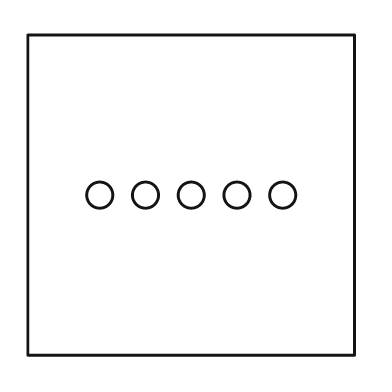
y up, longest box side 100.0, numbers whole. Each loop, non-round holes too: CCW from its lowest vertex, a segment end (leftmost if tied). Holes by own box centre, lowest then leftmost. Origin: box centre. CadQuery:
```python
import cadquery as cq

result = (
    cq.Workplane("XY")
    .moveTo(-50.0, -49.0)
    .lineTo(50.0, -49.0)
    .lineTo(50.0, 49.0)
    .lineTo(-50.0, 49.0)
    .close()
    .moveTo(-28.0, 0.0)
    .circle(4.0)
    .moveTo(-14.0, 0.0)
    .circle(4.0)
    .moveTo(0.0, 0.0)
    .circle(4.0)
    .moveTo(14.0, 0.0)
    .circle(4.0)
    .moveTo(28.0, 0.0)
    .circle(4.0)
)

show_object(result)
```